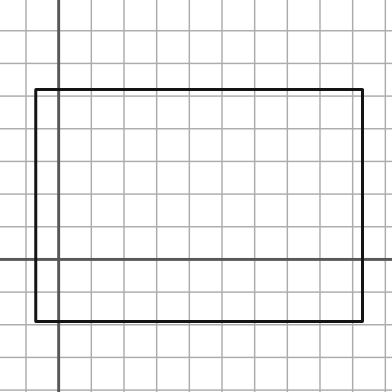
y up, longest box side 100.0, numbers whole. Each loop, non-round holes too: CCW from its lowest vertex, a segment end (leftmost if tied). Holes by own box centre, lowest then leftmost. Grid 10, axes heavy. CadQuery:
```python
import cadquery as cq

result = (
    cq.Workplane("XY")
    .moveTo(-7.0, -19.0)
    .lineTo(93.0, -19.0)
    .lineTo(93.0, 52.0)
    .lineTo(-7.0, 52.0)
    .close()
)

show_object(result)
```